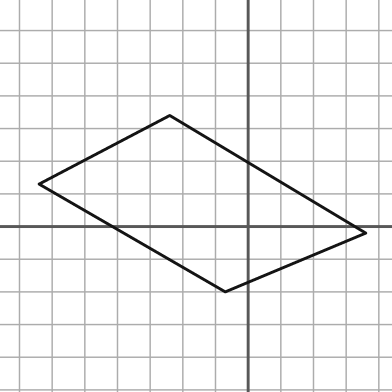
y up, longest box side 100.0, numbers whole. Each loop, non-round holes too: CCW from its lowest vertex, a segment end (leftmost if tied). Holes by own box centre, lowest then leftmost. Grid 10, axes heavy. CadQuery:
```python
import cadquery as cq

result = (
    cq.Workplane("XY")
    .moveTo(-7.0, -20.0)
    .lineTo(36.0, -2.0)
    .lineTo(-24.0, 34.0)
    .lineTo(-64.0, 13.0)
    .close()
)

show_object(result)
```